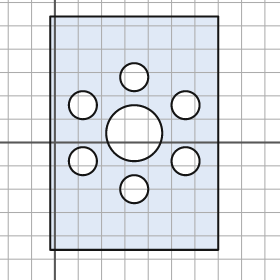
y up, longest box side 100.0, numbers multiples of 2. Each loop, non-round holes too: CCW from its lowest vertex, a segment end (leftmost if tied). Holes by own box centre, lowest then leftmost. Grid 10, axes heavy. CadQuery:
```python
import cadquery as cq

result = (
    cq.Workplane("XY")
    .moveTo(-2.0, -46.0)
    .lineTo(70.0, -46.0)
    .lineTo(70.0, 54.0)
    .lineTo(-2.0, 54.0)
    .close()
    .moveTo(34.0, -20.0)
    .circle(6.0)
    .moveTo(12.0, -8.0)
    .circle(6.0)
    .moveTo(56.0, -8.0)
    .circle(6.0)
    .moveTo(34.0, 4.0)
    .circle(12.0)
    .moveTo(12.0, 16.0)
    .circle(6.0)
    .moveTo(56.0, 16.0)
    .circle(6.0)
    .moveTo(34.0, 28.0)
    .circle(6.0)
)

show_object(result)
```